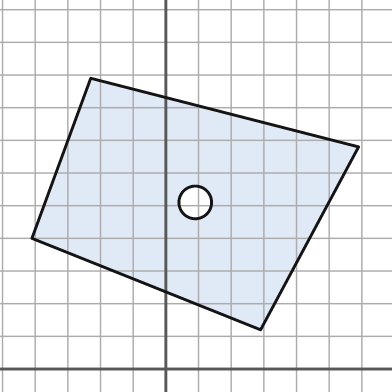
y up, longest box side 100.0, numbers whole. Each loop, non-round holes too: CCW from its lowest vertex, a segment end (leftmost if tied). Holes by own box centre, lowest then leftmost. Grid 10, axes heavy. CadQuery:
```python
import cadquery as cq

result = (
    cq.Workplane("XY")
    .moveTo(29.0, 12.0)
    .lineTo(59.0, 68.0)
    .lineTo(-23.0, 89.0)
    .lineTo(-41.0, 40.0)
    .close()
    .moveTo(9.0, 51.0)
    .circle(5.0)
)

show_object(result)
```